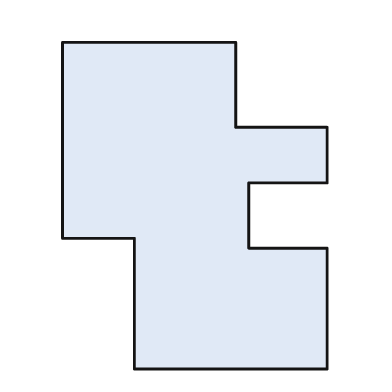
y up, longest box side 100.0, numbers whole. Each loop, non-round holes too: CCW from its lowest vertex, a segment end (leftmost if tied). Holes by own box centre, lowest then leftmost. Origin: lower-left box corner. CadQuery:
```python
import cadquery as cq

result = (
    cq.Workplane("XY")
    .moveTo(22.0, 0.0)
    .lineTo(81.0, 0.0)
    .lineTo(81.0, 37.0)
    .lineTo(57.0, 37.0)
    .lineTo(57.0, 57.0)
    .lineTo(81.0, 57.0)
    .lineTo(81.0, 74.0)
    .lineTo(53.0, 74.0)
    .lineTo(53.0, 100.0)
    .lineTo(0.0, 100.0)
    .lineTo(0.0, 40.0)
    .lineTo(22.0, 40.0)
    .close()
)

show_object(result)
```